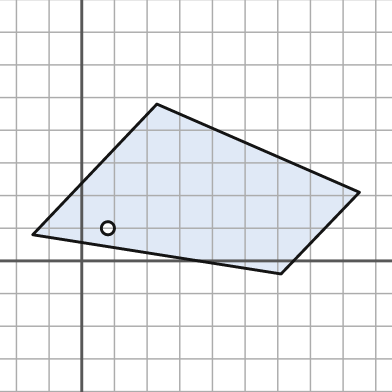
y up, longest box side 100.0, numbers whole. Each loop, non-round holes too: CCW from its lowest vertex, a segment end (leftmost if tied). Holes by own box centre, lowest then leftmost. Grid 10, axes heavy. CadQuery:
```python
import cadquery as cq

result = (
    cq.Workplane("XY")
    .moveTo(61.0, -4.0)
    .lineTo(85.0, 21.0)
    .lineTo(23.0, 48.0)
    .lineTo(-15.0, 8.0)
    .close()
    .moveTo(8.0, 10.0)
    .circle(2.0)
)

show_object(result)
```